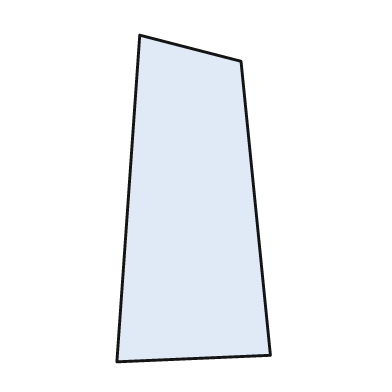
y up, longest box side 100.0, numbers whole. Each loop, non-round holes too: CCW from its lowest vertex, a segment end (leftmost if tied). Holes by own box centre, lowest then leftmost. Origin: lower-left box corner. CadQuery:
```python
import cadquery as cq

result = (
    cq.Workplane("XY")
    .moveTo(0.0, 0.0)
    .lineTo(47.0, 2.0)
    .lineTo(38.0, 92.0)
    .lineTo(7.0, 100.0)
    .close()
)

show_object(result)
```